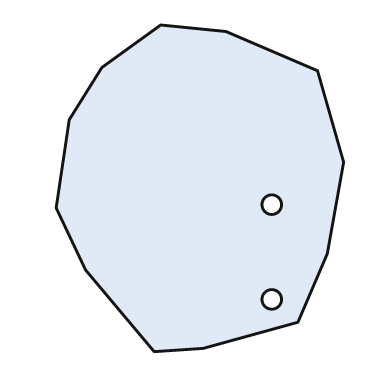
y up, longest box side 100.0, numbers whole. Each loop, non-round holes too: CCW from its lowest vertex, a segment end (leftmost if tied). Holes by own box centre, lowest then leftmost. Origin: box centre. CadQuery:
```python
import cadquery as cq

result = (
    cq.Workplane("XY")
    .moveTo(-14.0, -50.0)
    .lineTo(1.0, -49.0)
    .lineTo(30.0, -41.0)
    .lineTo(39.0, -20.0)
    .lineTo(44.0, 8.0)
    .lineTo(36.0, 36.0)
    .lineTo(8.0, 48.0)
    .lineTo(-12.0, 50.0)
    .lineTo(-30.0, 37.0)
    .lineTo(-40.0, 21.0)
    .lineTo(-44.0, -6.0)
    .lineTo(-35.0, -25.0)
    .close()
    .moveTo(22.0, -34.0)
    .circle(3.0)
    .moveTo(22.0, -5.0)
    .circle(3.0)
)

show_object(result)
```